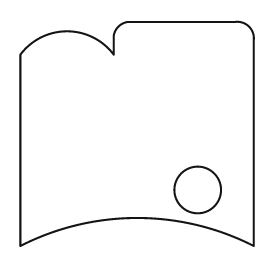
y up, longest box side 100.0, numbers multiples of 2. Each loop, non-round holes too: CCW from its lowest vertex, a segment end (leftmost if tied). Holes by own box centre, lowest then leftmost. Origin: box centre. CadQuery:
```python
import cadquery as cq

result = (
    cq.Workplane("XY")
    .moveTo(-50.0, -48.0)
    .threePointArc((0.0, -36.0), (50.0, -48.0))
    .lineTo(50.0, 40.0)
    .threePointArc((48.0, 46.0), (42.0, 48.0))
    .lineTo(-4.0, 48.0)
    .threePointArc((-8.0, 46.0), (-10.0, 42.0))
    .lineTo(-10.0, 34.0)
    .threePointArc((-30.0, 44.0), (-50.0, 34.0))
    .close()
    .moveTo(26.0, -24.0)
    .circle(10.0)
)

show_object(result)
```